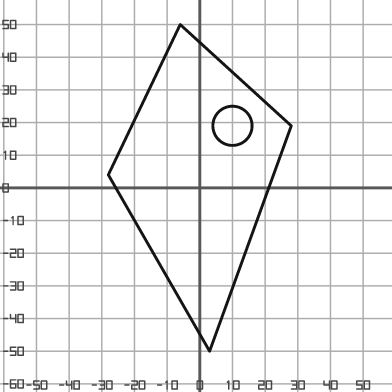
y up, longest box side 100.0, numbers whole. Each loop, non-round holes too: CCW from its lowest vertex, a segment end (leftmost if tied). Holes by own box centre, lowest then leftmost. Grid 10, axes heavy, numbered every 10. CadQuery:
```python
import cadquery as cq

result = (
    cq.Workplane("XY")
    .moveTo(3.0, -50.0)
    .lineTo(28.0, 19.0)
    .lineTo(-6.0, 50.0)
    .lineTo(-28.0, 4.0)
    .close()
    .moveTo(10.0, 19.0)
    .circle(6.0)
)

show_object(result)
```